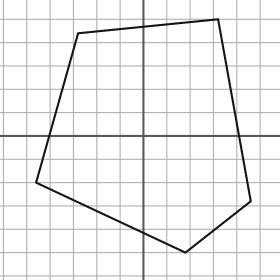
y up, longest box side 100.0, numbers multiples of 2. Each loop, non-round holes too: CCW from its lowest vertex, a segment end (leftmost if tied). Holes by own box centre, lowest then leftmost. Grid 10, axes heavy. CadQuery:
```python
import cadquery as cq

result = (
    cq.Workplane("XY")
    .moveTo(18.0, -50.0)
    .lineTo(46.0, -28.0)
    .lineTo(32.0, 50.0)
    .lineTo(-28.0, 44.0)
    .lineTo(-46.0, -20.0)
    .close()
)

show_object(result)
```